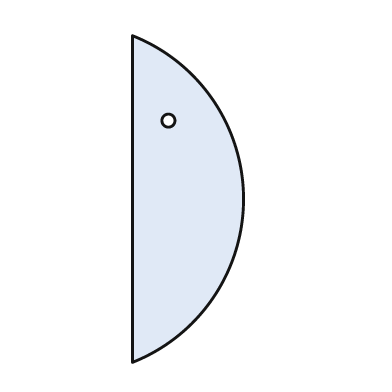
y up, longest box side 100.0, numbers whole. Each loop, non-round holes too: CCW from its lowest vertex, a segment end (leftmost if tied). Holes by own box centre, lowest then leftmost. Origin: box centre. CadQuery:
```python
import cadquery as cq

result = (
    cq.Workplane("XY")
    .moveTo(-17.0, -50.0)
    .threePointArc((17.0, 0.0), (-17.0, 50.0))
    .close()
    .moveTo(-6.0, 24.0)
    .circle(2.0)
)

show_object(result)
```